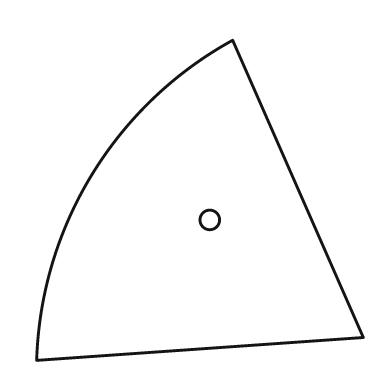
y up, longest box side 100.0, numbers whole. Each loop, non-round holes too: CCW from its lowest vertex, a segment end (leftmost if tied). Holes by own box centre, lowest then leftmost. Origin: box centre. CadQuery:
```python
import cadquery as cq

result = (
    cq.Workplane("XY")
    .moveTo(-50.0, -49.0)
    .lineTo(50.0, -42.0)
    .lineTo(10.0, 49.0)
    .threePointArc((-33.0, 8.0), (-50.0, -49.0))
    .close()
    .moveTo(3.0, -6.0)
    .circle(3.0)
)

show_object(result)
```